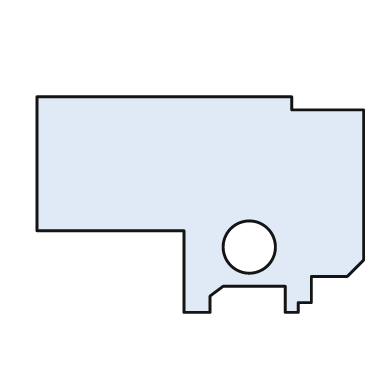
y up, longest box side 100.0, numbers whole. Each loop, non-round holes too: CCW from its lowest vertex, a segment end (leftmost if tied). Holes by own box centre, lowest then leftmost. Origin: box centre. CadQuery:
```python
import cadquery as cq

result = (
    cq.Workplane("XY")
    .moveTo(-5.0, -33.0)
    .lineTo(3.0, -33.0)
    .lineTo(3.0, -28.0)
    .lineTo(7.0, -25.0)
    .lineTo(26.0, -25.0)
    .lineTo(26.0, -33.0)
    .lineTo(30.0, -33.0)
    .lineTo(30.0, -30.0)
    .lineTo(34.0, -30.0)
    .lineTo(34.0, -22.0)
    .lineTo(45.0, -22.0)
    .lineTo(50.0, -17.0)
    .lineTo(50.0, 29.0)
    .lineTo(28.0, 29.0)
    .lineTo(28.0, 33.0)
    .lineTo(-50.0, 33.0)
    .lineTo(-50.0, -8.0)
    .lineTo(-5.0, -8.0)
    .close()
    .moveTo(15.0, -13.0)
    .circle(8.0)
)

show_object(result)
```